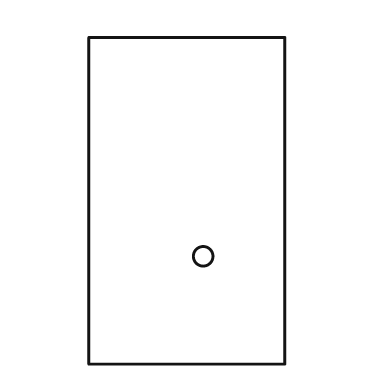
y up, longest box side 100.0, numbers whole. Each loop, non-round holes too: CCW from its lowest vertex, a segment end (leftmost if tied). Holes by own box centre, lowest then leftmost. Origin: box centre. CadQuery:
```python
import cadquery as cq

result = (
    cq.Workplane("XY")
    .moveTo(-30.0, -50.0)
    .lineTo(30.0, -50.0)
    .lineTo(30.0, 50.0)
    .lineTo(-30.0, 50.0)
    .close()
    .moveTo(5.0, -17.0)
    .circle(3.0)
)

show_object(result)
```